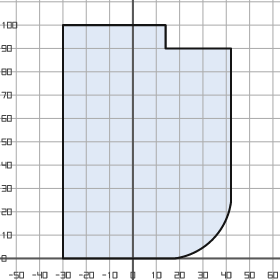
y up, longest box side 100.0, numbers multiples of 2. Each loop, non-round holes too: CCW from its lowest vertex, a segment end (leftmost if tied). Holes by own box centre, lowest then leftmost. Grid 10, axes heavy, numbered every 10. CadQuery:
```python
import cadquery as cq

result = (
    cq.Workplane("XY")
    .moveTo(-30.0, 0.0)
    .lineTo(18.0, 0.0)
    .threePointArc((34.0, 8.0), (42.0, 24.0))
    .lineTo(42.0, 90.0)
    .lineTo(14.0, 90.0)
    .lineTo(14.0, 100.0)
    .lineTo(-30.0, 100.0)
    .close()
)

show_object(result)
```